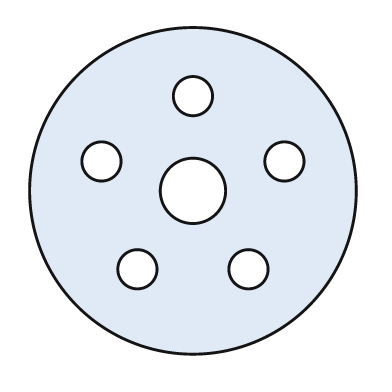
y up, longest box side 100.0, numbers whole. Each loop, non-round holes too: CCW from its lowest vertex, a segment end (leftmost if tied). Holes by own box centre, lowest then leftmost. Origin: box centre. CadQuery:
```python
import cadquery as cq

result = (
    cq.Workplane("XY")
    .moveTo(0.0, 0.0)
    .circle(50.0)
    .moveTo(-17.0, -24.0)
    .circle(6.0)
    .moveTo(17.0, -24.0)
    .circle(6.0)
    .moveTo(0.0, 0.0)
    .circle(10.0)
    .moveTo(-28.0, 9.0)
    .circle(6.0)
    .moveTo(28.0, 9.0)
    .circle(6.0)
    .moveTo(0.0, 29.0)
    .circle(6.0)
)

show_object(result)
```